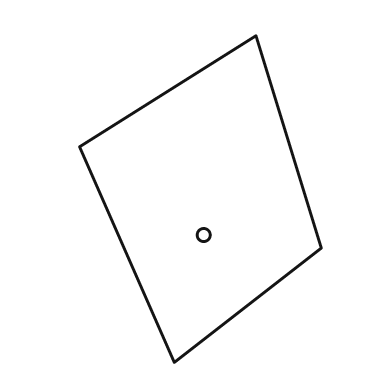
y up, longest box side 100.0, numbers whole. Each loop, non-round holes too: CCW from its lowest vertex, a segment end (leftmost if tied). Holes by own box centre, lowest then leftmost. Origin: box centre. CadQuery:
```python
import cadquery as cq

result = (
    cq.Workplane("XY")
    .moveTo(-8.0, -50.0)
    .lineTo(37.0, -15.0)
    .lineTo(17.0, 50.0)
    .lineTo(-37.0, 16.0)
    .close()
    .moveTo(1.0, -11.0)
    .circle(2.0)
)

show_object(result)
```